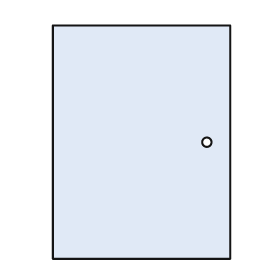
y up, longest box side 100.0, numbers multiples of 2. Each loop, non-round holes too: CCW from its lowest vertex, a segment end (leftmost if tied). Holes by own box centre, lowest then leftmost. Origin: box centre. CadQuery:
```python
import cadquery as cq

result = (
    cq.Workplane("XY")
    .moveTo(-38.0, -50.0)
    .lineTo(38.0, -50.0)
    .lineTo(38.0, 50.0)
    .lineTo(-38.0, 50.0)
    .close()
    .moveTo(28.0, 0.0)
    .circle(2.0)
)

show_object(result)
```